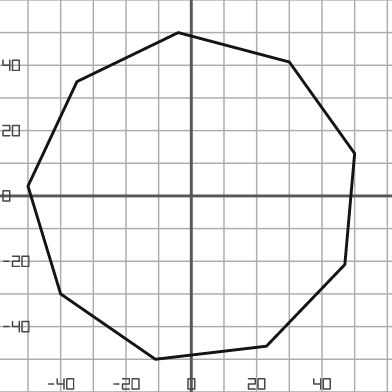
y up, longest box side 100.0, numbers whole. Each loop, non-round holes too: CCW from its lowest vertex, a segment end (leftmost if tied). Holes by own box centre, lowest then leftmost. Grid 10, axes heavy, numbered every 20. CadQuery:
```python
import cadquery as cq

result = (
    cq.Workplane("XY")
    .moveTo(-11.0, -50.0)
    .lineTo(23.0, -46.0)
    .lineTo(47.0, -21.0)
    .lineTo(50.0, 13.0)
    .lineTo(30.0, 41.0)
    .lineTo(-4.0, 50.0)
    .lineTo(-35.0, 35.0)
    .lineTo(-50.0, 3.0)
    .lineTo(-40.0, -30.0)
    .close()
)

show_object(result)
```